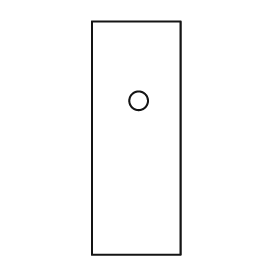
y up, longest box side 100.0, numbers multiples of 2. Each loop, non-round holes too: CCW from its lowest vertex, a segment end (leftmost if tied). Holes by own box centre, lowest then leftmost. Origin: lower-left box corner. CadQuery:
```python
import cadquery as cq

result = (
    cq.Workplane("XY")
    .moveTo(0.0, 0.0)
    .lineTo(38.0, 0.0)
    .lineTo(38.0, 100.0)
    .lineTo(0.0, 100.0)
    .close()
    .moveTo(20.0, 66.0)
    .circle(4.0)
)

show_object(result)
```